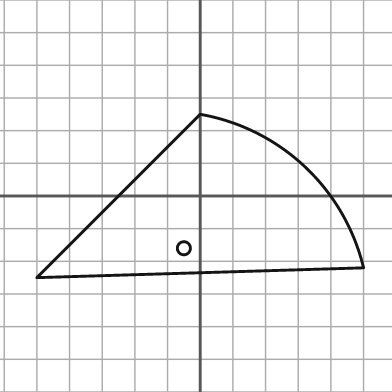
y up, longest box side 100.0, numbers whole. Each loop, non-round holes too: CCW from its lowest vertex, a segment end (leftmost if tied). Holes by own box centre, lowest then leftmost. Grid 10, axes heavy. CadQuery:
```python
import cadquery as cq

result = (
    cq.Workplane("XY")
    .moveTo(-50.0, -25.0)
    .lineTo(50.0, -22.0)
    .threePointArc((32.0, 9.0), (0.0, 25.0))
    .close()
    .moveTo(-5.0, -16.0)
    .circle(2.0)
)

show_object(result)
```